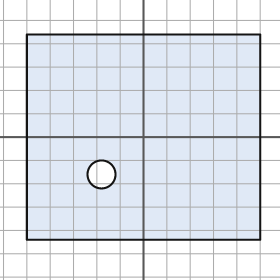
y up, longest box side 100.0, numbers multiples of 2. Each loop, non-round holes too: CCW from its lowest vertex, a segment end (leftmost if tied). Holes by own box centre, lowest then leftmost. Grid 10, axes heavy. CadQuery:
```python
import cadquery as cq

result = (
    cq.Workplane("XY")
    .moveTo(-50.0, -44.0)
    .lineTo(50.0, -44.0)
    .lineTo(50.0, 44.0)
    .lineTo(-50.0, 44.0)
    .close()
    .moveTo(-18.0, -16.0)
    .circle(6.0)
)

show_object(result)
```